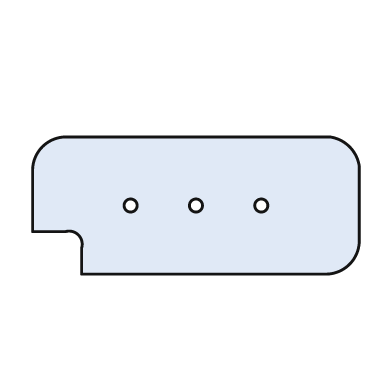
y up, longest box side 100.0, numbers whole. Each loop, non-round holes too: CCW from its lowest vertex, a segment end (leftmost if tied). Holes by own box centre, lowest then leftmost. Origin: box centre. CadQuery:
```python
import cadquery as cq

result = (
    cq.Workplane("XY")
    .moveTo(-35.0, -21.0)
    .lineTo(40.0, -21.0)
    .threePointArc((47.0, -18.0), (50.0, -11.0))
    .lineTo(50.0, 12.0)
    .threePointArc((47.0, 18.0), (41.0, 21.0))
    .lineTo(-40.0, 21.0)
    .threePointArc((-47.0, 18.0), (-50.0, 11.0))
    .lineTo(-50.0, -8.0)
    .lineTo(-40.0, -8.0)
    .threePointArc((-36.0, -9.0), (-35.0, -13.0))
    .close()
    .moveTo(-20.0, 0.0)
    .circle(2.0)
    .moveTo(0.0, 0.0)
    .circle(2.0)
    .moveTo(20.0, 0.0)
    .circle(2.0)
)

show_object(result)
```